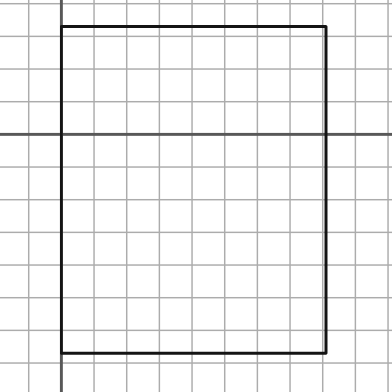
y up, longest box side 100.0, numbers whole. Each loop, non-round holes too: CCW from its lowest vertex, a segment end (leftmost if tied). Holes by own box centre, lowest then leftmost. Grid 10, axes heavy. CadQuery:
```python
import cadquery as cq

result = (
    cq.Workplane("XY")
    .moveTo(0.0, -67.0)
    .lineTo(81.0, -67.0)
    .lineTo(81.0, 33.0)
    .lineTo(0.0, 33.0)
    .close()
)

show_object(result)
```